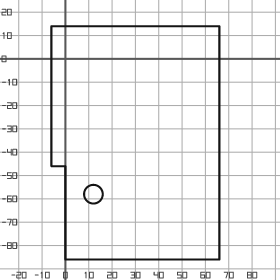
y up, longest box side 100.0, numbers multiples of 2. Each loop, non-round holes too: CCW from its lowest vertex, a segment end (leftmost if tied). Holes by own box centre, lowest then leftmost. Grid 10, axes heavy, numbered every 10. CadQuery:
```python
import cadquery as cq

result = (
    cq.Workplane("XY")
    .moveTo(0.0, -86.0)
    .lineTo(66.0, -86.0)
    .lineTo(66.0, 14.0)
    .lineTo(-6.0, 14.0)
    .lineTo(-6.0, -46.0)
    .lineTo(0.0, -46.0)
    .close()
    .moveTo(12.0, -58.0)
    .circle(4.0)
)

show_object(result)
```